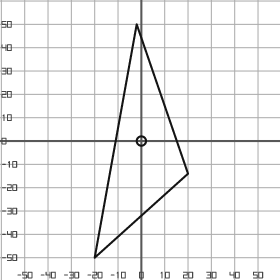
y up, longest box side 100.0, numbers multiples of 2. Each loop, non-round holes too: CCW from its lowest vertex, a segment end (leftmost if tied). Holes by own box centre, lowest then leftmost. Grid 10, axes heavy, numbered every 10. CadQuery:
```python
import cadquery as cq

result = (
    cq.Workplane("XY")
    .moveTo(-20.0, -50.0)
    .lineTo(20.0, -14.0)
    .lineTo(-2.0, 50.0)
    .close()
    .moveTo(0.0, 0.0)
    .circle(2.0)
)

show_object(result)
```